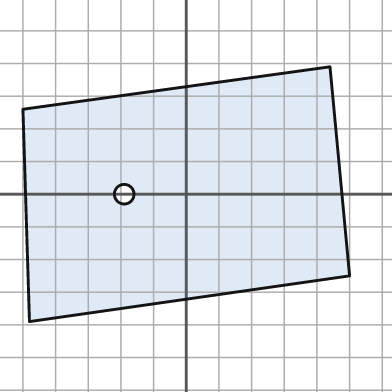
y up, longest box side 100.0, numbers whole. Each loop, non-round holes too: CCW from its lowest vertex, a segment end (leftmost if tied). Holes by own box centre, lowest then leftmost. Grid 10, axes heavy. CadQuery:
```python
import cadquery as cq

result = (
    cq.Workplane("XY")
    .moveTo(-48.0, -39.0)
    .lineTo(50.0, -25.0)
    .lineTo(44.0, 39.0)
    .lineTo(-50.0, 26.0)
    .close()
    .moveTo(-19.0, 0.0)
    .circle(3.0)
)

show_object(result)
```